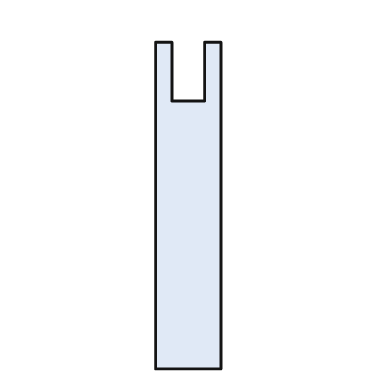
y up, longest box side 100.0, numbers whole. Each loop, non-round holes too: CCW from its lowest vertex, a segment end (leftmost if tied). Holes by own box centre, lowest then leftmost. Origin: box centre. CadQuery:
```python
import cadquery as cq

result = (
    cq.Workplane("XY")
    .moveTo(-10.0, -50.0)
    .lineTo(10.0, -50.0)
    .lineTo(10.0, 50.0)
    .lineTo(5.0, 50.0)
    .lineTo(5.0, 32.0)
    .lineTo(-5.0, 32.0)
    .lineTo(-5.0, 50.0)
    .lineTo(-10.0, 50.0)
    .close()
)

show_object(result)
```